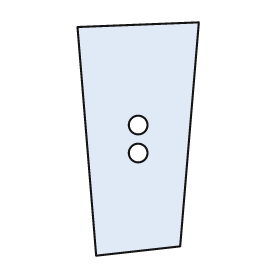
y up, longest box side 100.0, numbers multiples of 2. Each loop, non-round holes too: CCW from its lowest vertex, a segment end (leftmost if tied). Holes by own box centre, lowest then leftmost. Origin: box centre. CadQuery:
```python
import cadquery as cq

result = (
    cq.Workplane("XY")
    .moveTo(-18.0, -50.0)
    .lineTo(18.0, -46.0)
    .lineTo(26.0, 50.0)
    .lineTo(-26.0, 48.0)
    .close()
    .moveTo(0.0, -6.0)
    .circle(4.0)
    .moveTo(0.0, 6.0)
    .circle(4.0)
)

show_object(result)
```